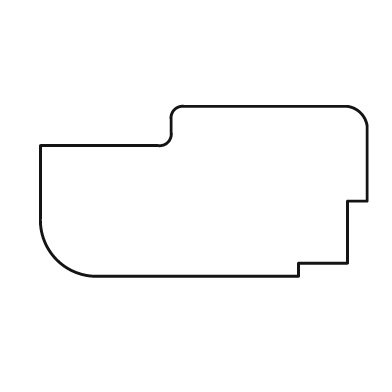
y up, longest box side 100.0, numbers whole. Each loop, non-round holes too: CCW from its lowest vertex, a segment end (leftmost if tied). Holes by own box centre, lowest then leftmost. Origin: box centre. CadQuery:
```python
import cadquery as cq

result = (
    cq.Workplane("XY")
    .moveTo(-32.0, -26.0)
    .lineTo(29.0, -26.0)
    .lineTo(29.0, -22.0)
    .lineTo(44.0, -22.0)
    .lineTo(44.0, -3.0)
    .lineTo(50.0, -3.0)
    .lineTo(50.0, 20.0)
    .threePointArc((48.0, 24.0), (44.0, 26.0))
    .lineTo(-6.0, 26.0)
    .threePointArc((-9.0, 25.0), (-10.0, 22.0))
    .lineTo(-10.0, 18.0)
    .threePointArc((-11.0, 15.0), (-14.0, 14.0))
    .lineTo(-50.0, 14.0)
    .lineTo(-50.0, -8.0)
    .threePointArc((-45.0, -21.0), (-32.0, -26.0))
    .close()
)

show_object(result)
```